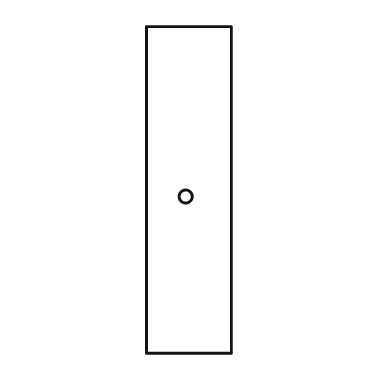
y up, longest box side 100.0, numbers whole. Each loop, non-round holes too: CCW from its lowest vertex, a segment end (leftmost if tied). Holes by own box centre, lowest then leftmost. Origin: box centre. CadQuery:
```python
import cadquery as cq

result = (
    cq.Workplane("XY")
    .moveTo(-13.0, -50.0)
    .lineTo(13.0, -50.0)
    .lineTo(13.0, 50.0)
    .lineTo(-13.0, 50.0)
    .close()
    .moveTo(-1.0, -2.0)
    .circle(2.0)
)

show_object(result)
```